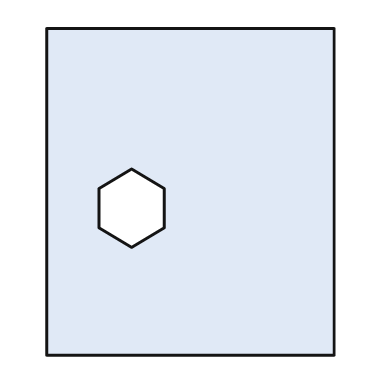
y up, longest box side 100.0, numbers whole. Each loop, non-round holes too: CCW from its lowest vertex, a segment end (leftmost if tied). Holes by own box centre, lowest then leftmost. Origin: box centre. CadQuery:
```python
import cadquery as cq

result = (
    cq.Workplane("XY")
    .moveTo(-44.0, -50.0)
    .lineTo(44.0, -50.0)
    .lineTo(44.0, 50.0)
    .lineTo(-44.0, 50.0)
    .close()
    .moveTo(-18.0, -17.0)
    .lineTo(-8.0, -11.0)
    .lineTo(-8.0, 1.0)
    .lineTo(-18.0, 7.0)
    .lineTo(-28.0, 1.0)
    .lineTo(-28.0, -11.0)
    .close()
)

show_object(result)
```